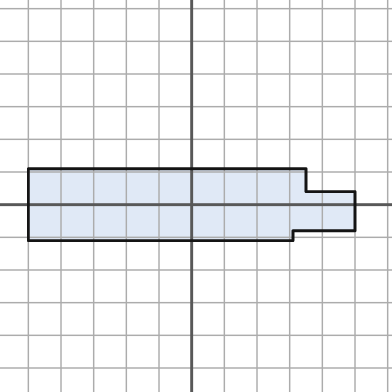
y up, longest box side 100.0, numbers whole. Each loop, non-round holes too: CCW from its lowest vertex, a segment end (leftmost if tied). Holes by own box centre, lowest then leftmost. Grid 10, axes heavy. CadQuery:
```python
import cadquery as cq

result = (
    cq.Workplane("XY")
    .moveTo(-50.0, -11.0)
    .lineTo(31.0, -11.0)
    .lineTo(31.0, -8.0)
    .lineTo(50.0, -8.0)
    .lineTo(50.0, 4.0)
    .lineTo(35.0, 4.0)
    .lineTo(35.0, 11.0)
    .lineTo(-50.0, 11.0)
    .close()
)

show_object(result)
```